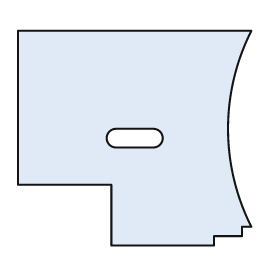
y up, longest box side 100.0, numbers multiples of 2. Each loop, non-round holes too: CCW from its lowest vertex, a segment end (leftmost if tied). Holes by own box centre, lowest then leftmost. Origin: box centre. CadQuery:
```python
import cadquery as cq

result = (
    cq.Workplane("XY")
    .moveTo(-10.0, -46.0)
    .lineTo(34.0, -46.0)
    .lineTo(34.0, -42.0)
    .lineTo(46.0, -42.0)
    .lineTo(46.0, -38.0)
    .lineTo(50.0, -38.0)
    .threePointArc((40.0, 4.0), (50.0, 46.0))
    .lineTo(-50.0, 46.0)
    .lineTo(-50.0, -20.0)
    .lineTo(-10.0, -20.0)
    .close()
    .moveTo(-8.0, -4.0)
    .lineTo(8.0, -4.0)
    .threePointArc((12.0, 0.0), (8.0, 4.0))
    .lineTo(-8.0, 4.0)
    .threePointArc((-12.0, 0.0), (-8.0, -4.0))
    .close()
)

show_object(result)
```